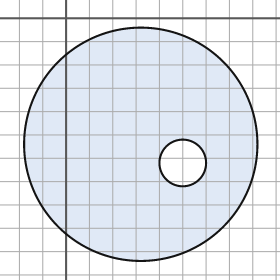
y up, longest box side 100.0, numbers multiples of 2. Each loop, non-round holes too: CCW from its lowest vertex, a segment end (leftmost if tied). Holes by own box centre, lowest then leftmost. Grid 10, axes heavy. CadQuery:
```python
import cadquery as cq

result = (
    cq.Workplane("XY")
    .moveTo(32.0, -54.0)
    .circle(50.0)
    .moveTo(50.0, -62.0)
    .circle(10.0)
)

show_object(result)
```